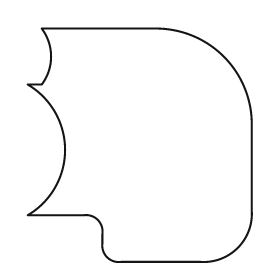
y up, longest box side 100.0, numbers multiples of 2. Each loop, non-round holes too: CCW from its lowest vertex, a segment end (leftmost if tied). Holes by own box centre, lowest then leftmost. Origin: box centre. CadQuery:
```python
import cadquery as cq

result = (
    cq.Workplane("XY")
    .moveTo(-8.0, -50.0)
    .lineTo(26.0, -50.0)
    .threePointArc((42.0, -44.0), (48.0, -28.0))
    .lineTo(48.0, 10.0)
    .threePointArc((36.0, 38.0), (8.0, 50.0))
    .lineTo(-42.0, 50.0)
    .threePointArc((-38.0, 38.0), (-42.0, 26.0))
    .lineTo(-48.0, 26.0)
    .threePointArc((-32.0, -2.0), (-48.0, -30.0))
    .lineTo(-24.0, -30.0)
    .threePointArc((-18.0, -32.0), (-16.0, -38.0))
    .lineTo(-16.0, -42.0)
    .threePointArc((-14.0, -48.0), (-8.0, -50.0))
    .close()
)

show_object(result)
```